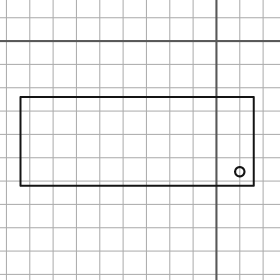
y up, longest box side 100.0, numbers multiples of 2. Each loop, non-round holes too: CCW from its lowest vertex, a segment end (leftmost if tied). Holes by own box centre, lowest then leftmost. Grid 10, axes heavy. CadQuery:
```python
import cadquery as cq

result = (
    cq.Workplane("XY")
    .moveTo(-84.0, -62.0)
    .lineTo(16.0, -62.0)
    .lineTo(16.0, -24.0)
    .lineTo(-84.0, -24.0)
    .close()
    .moveTo(10.0, -56.0)
    .circle(2.0)
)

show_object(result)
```